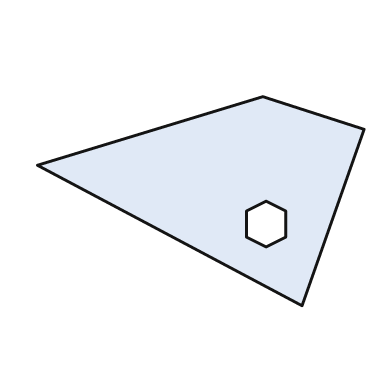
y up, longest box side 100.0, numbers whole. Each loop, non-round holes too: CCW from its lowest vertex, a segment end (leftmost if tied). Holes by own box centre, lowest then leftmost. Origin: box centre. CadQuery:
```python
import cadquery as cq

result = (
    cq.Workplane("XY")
    .moveTo(31.0, -32.0)
    .lineTo(50.0, 22.0)
    .lineTo(19.0, 32.0)
    .lineTo(-50.0, 11.0)
    .close()
    .moveTo(20.0, -14.0)
    .lineTo(26.0, -11.0)
    .lineTo(26.0, -3.0)
    .lineTo(20.0, 0.0)
    .lineTo(14.0, -3.0)
    .lineTo(14.0, -11.0)
    .close()
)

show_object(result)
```